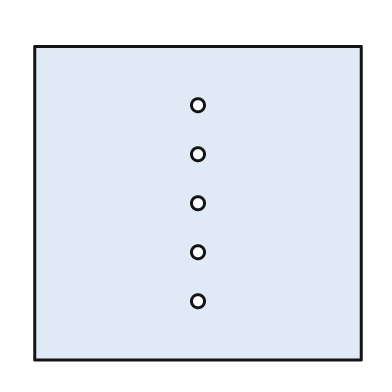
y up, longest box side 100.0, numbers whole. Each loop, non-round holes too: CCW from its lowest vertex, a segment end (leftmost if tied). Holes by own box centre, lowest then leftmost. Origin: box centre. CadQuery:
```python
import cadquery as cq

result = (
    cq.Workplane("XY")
    .moveTo(-50.0, -48.0)
    .lineTo(50.0, -48.0)
    .lineTo(50.0, 48.0)
    .lineTo(-50.0, 48.0)
    .close()
    .moveTo(0.0, -30.0)
    .circle(2.0)
    .moveTo(0.0, -15.0)
    .circle(2.0)
    .moveTo(0.0, 0.0)
    .circle(2.0)
    .moveTo(0.0, 15.0)
    .circle(2.0)
    .moveTo(0.0, 30.0)
    .circle(2.0)
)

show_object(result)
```